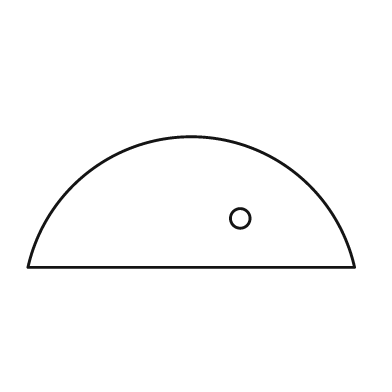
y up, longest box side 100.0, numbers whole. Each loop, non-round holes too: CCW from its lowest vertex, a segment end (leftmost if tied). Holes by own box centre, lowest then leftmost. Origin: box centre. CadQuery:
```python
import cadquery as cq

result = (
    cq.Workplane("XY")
    .moveTo(-50.0, -20.0)
    .lineTo(50.0, -20.0)
    .threePointArc((0.0, 20.0), (-50.0, -20.0))
    .close()
    .moveTo(15.0, -5.0)
    .circle(3.0)
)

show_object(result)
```